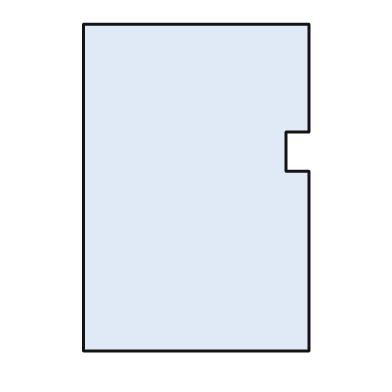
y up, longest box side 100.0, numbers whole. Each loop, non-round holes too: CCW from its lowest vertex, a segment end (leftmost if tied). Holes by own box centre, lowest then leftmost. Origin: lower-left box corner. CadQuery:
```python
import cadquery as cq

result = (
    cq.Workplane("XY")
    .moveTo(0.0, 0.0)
    .lineTo(69.0, 0.0)
    .lineTo(69.0, 55.0)
    .lineTo(62.0, 55.0)
    .lineTo(62.0, 67.0)
    .lineTo(69.0, 67.0)
    .lineTo(69.0, 100.0)
    .lineTo(0.0, 100.0)
    .close()
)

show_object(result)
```